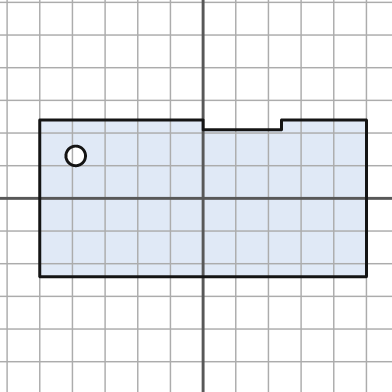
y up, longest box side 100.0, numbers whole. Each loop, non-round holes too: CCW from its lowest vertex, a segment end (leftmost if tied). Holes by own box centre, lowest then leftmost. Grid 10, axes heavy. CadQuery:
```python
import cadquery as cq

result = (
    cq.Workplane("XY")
    .moveTo(-50.0, -24.0)
    .lineTo(50.0, -24.0)
    .lineTo(50.0, 24.0)
    .lineTo(24.0, 24.0)
    .lineTo(24.0, 21.0)
    .lineTo(0.0, 21.0)
    .lineTo(0.0, 24.0)
    .lineTo(-50.0, 24.0)
    .close()
    .moveTo(-39.0, 13.0)
    .circle(3.0)
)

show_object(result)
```